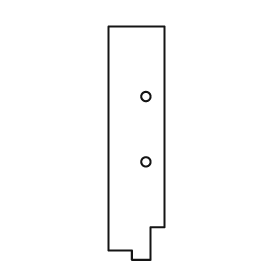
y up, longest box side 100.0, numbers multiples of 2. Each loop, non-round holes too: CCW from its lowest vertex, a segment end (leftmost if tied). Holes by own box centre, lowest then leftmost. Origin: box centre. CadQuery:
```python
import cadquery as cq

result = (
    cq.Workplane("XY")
    .moveTo(-2.0, -50.0)
    .lineTo(6.0, -50.0)
    .lineTo(6.0, -36.0)
    .lineTo(12.0, -36.0)
    .lineTo(12.0, 50.0)
    .lineTo(-12.0, 50.0)
    .lineTo(-12.0, -46.0)
    .lineTo(-2.0, -46.0)
    .close()
    .moveTo(4.0, -8.0)
    .circle(2.0)
    .moveTo(4.0, 20.0)
    .circle(2.0)
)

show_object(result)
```